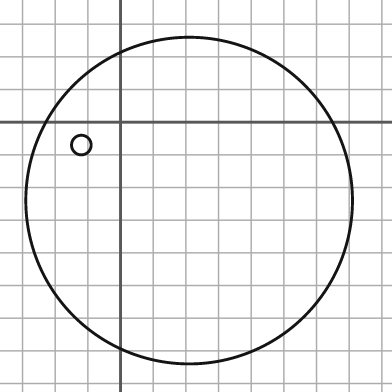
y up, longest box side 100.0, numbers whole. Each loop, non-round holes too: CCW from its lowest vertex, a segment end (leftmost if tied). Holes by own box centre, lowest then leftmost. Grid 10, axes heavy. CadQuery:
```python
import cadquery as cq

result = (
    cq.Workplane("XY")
    .moveTo(21.0, -24.0)
    .circle(50.0)
    .moveTo(-12.0, -7.0)
    .circle(3.0)
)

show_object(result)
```